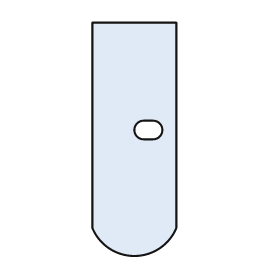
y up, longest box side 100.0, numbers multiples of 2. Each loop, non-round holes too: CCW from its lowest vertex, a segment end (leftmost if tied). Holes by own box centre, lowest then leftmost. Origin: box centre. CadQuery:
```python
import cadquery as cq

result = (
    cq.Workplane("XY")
    .moveTo(-18.0, -38.0)
    .threePointArc((0.0, -50.0), (18.0, -38.0))
    .lineTo(18.0, 50.0)
    .lineTo(-18.0, 50.0)
    .close()
    .moveTo(4.0, 0.0)
    .lineTo(8.0, 0.0)
    .threePointArc((12.0, 4.0), (8.0, 8.0))
    .lineTo(4.0, 8.0)
    .threePointArc((0.0, 4.0), (4.0, 0.0))
    .close()
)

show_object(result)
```